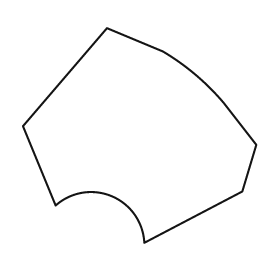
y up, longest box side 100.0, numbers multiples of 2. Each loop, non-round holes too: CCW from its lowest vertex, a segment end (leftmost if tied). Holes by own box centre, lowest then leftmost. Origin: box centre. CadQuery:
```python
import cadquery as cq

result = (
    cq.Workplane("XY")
    .moveTo(2.0, -46.0)
    .lineTo(44.0, -24.0)
    .lineTo(50.0, -4.0)
    .lineTo(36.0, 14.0)
    .threePointArc((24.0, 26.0), (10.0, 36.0))
    .lineTo(-14.0, 46.0)
    .lineTo(-50.0, 4.0)
    .lineTo(-36.0, -30.0)
    .threePointArc((-12.0, -26.0), (2.0, -46.0))
    .close()
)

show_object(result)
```